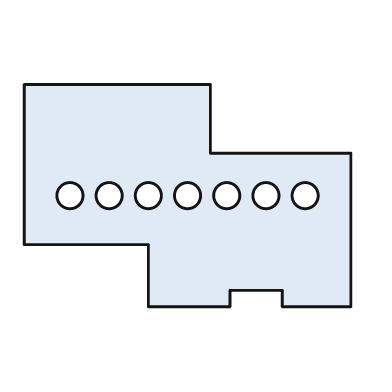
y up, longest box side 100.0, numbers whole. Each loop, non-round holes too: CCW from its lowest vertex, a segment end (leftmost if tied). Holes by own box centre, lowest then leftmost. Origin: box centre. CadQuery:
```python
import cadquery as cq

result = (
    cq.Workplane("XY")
    .moveTo(-12.0, -34.0)
    .lineTo(13.0, -34.0)
    .lineTo(13.0, -29.0)
    .lineTo(29.0, -29.0)
    .lineTo(29.0, -34.0)
    .lineTo(50.0, -34.0)
    .lineTo(50.0, 13.0)
    .lineTo(7.0, 13.0)
    .lineTo(7.0, 34.0)
    .lineTo(-50.0, 34.0)
    .lineTo(-50.0, -15.0)
    .lineTo(-12.0, -15.0)
    .close()
    .moveTo(-36.0, 0.0)
    .circle(4.0)
    .moveTo(-24.0, 0.0)
    .circle(4.0)
    .moveTo(-12.0, 0.0)
    .circle(4.0)
    .moveTo(0.0, 0.0)
    .circle(4.0)
    .moveTo(12.0, 0.0)
    .circle(4.0)
    .moveTo(24.0, 0.0)
    .circle(4.0)
    .moveTo(36.0, 0.0)
    .circle(4.0)
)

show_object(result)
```